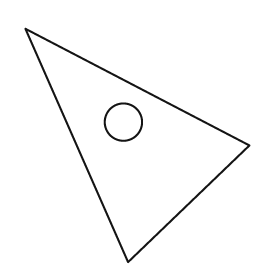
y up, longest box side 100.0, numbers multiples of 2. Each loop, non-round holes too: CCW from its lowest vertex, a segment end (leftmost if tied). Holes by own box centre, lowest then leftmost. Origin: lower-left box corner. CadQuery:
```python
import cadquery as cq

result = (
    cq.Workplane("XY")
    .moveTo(44.0, 0.0)
    .lineTo(96.0, 50.0)
    .lineTo(0.0, 100.0)
    .close()
    .moveTo(42.0, 60.0)
    .circle(8.0)
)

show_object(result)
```